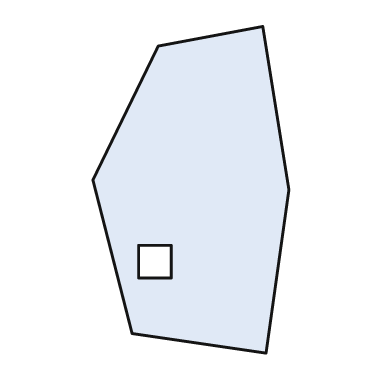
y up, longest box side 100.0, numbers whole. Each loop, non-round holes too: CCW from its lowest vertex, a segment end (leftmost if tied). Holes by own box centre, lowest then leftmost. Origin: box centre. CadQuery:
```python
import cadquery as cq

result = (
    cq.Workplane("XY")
    .moveTo(23.0, -50.0)
    .lineTo(30.0, 0.0)
    .lineTo(22.0, 50.0)
    .lineTo(-10.0, 44.0)
    .lineTo(-30.0, 3.0)
    .lineTo(-18.0, -44.0)
    .close()
    .moveTo(-16.0, -27.0)
    .lineTo(-6.0, -27.0)
    .lineTo(-6.0, -17.0)
    .lineTo(-16.0, -17.0)
    .close()
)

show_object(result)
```